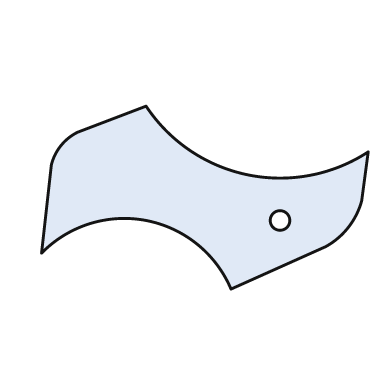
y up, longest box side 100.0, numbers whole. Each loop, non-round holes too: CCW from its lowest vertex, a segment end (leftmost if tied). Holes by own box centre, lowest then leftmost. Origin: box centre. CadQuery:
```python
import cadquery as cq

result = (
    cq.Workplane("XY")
    .moveTo(8.0, -28.0)
    .lineTo(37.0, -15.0)
    .threePointArc((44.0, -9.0), (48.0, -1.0))
    .lineTo(50.0, 14.0)
    .threePointArc((13.0, 7.0), (-18.0, 28.0))
    .lineTo(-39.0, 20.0)
    .threePointArc((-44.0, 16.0), (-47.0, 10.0))
    .lineTo(-50.0, -17.0)
    .threePointArc((-18.0, -7.0), (8.0, -28.0))
    .close()
    .moveTo(23.0, -7.0)
    .circle(3.0)
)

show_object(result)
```